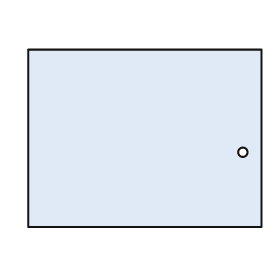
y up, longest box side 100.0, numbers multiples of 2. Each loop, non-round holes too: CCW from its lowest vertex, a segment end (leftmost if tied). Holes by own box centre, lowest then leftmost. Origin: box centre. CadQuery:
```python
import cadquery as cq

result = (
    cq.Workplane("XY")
    .moveTo(-50.0, -38.0)
    .lineTo(50.0, -38.0)
    .lineTo(50.0, 38.0)
    .lineTo(-50.0, 38.0)
    .close()
    .moveTo(42.0, -6.0)
    .circle(2.0)
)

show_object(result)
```